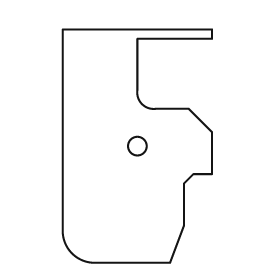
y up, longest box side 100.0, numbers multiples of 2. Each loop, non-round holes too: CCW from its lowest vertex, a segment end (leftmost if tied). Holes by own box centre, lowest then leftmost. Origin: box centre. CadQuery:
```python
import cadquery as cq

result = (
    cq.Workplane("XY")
    .moveTo(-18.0, -50.0)
    .lineTo(14.0, -50.0)
    .lineTo(20.0, -34.0)
    .lineTo(20.0, -16.0)
    .lineTo(24.0, -12.0)
    .lineTo(32.0, -12.0)
    .lineTo(32.0, 6.0)
    .lineTo(22.0, 16.0)
    .lineTo(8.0, 16.0)
    .threePointArc((2.0, 18.0), (0.0, 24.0))
    .lineTo(0.0, 46.0)
    .lineTo(32.0, 46.0)
    .lineTo(32.0, 50.0)
    .lineTo(-32.0, 50.0)
    .lineTo(-32.0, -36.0)
    .threePointArc((-28.0, -46.0), (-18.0, -50.0))
    .close()
    .moveTo(0.0, 0.0)
    .circle(4.0)
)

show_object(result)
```